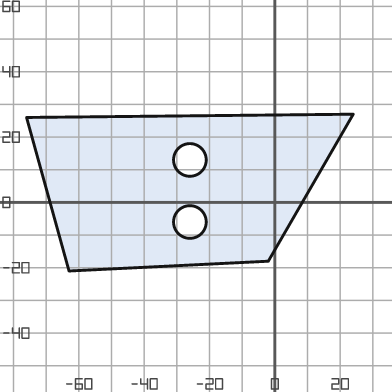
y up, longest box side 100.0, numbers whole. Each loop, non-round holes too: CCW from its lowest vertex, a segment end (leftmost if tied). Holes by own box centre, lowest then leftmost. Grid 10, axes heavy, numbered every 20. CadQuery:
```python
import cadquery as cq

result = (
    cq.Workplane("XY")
    .moveTo(-63.0, -21.0)
    .lineTo(-2.0, -18.0)
    .lineTo(24.0, 27.0)
    .lineTo(-76.0, 26.0)
    .close()
    .moveTo(-26.0, -6.0)
    .circle(5.0)
    .moveTo(-26.0, 13.0)
    .circle(5.0)
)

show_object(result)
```